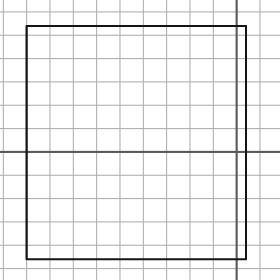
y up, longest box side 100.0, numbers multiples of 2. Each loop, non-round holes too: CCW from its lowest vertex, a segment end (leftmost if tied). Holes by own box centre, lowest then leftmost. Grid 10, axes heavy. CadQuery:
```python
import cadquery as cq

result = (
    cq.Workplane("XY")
    .moveTo(-90.0, -46.0)
    .lineTo(4.0, -46.0)
    .lineTo(4.0, 54.0)
    .lineTo(-90.0, 54.0)
    .close()
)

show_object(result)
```